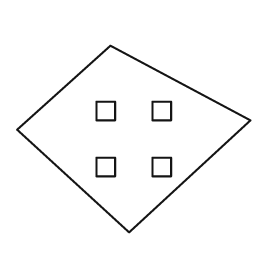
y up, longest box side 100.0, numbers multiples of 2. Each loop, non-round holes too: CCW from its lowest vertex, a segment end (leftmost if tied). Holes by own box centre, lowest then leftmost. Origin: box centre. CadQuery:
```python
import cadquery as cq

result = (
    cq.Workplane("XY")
    .moveTo(-2.0, -40.0)
    .lineTo(50.0, 8.0)
    .lineTo(-10.0, 40.0)
    .lineTo(-50.0, 4.0)
    .close()
    .moveTo(-16.0, -16.0)
    .lineTo(-8.0, -16.0)
    .lineTo(-8.0, -8.0)
    .lineTo(-16.0, -8.0)
    .close()
    .moveTo(8.0, -16.0)
    .lineTo(16.0, -16.0)
    .lineTo(16.0, -8.0)
    .lineTo(8.0, -8.0)
    .close()
    .moveTo(-16.0, 8.0)
    .lineTo(-8.0, 8.0)
    .lineTo(-8.0, 16.0)
    .lineTo(-16.0, 16.0)
    .close()
    .moveTo(8.0, 8.0)
    .lineTo(16.0, 8.0)
    .lineTo(16.0, 16.0)
    .lineTo(8.0, 16.0)
    .close()
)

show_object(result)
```